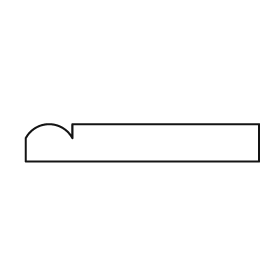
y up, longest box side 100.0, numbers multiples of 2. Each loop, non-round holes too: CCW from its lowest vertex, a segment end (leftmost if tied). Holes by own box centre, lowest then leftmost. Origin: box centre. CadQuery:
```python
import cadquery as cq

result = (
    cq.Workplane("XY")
    .moveTo(-50.0, -8.0)
    .lineTo(50.0, -8.0)
    .lineTo(50.0, 8.0)
    .lineTo(-30.0, 8.0)
    .lineTo(-30.0, 2.0)
    .threePointArc((-40.0, 8.0), (-50.0, 2.0))
    .close()
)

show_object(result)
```